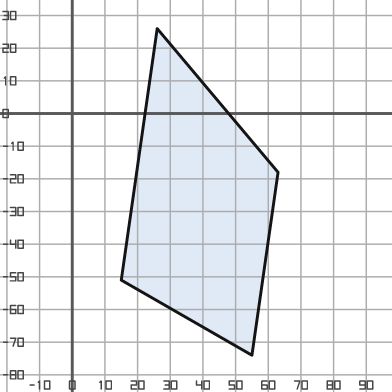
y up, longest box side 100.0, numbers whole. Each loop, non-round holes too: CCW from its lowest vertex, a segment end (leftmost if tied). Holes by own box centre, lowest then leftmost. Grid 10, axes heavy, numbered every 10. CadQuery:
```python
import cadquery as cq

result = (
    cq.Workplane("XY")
    .moveTo(55.0, -74.0)
    .lineTo(63.0, -18.0)
    .lineTo(26.0, 26.0)
    .lineTo(15.0, -51.0)
    .close()
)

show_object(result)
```